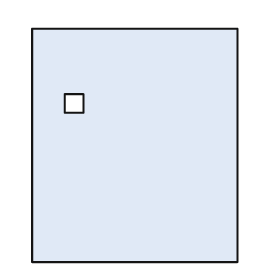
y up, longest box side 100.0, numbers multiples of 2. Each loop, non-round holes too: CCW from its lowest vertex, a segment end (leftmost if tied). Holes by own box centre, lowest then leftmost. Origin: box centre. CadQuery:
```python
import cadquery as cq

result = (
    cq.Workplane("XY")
    .moveTo(-44.0, -50.0)
    .lineTo(44.0, -50.0)
    .lineTo(44.0, 50.0)
    .lineTo(-44.0, 50.0)
    .close()
    .moveTo(-30.0, 14.0)
    .lineTo(-22.0, 14.0)
    .lineTo(-22.0, 22.0)
    .lineTo(-30.0, 22.0)
    .close()
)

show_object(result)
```